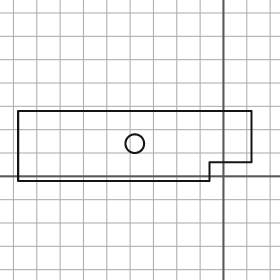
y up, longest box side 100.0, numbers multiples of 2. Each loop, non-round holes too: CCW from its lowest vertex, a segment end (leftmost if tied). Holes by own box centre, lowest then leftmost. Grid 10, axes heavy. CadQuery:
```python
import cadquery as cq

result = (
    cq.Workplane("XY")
    .moveTo(-88.0, -2.0)
    .lineTo(-6.0, -2.0)
    .lineTo(-6.0, 6.0)
    .lineTo(12.0, 6.0)
    .lineTo(12.0, 28.0)
    .lineTo(-88.0, 28.0)
    .close()
    .moveTo(-38.0, 14.0)
    .circle(4.0)
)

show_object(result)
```